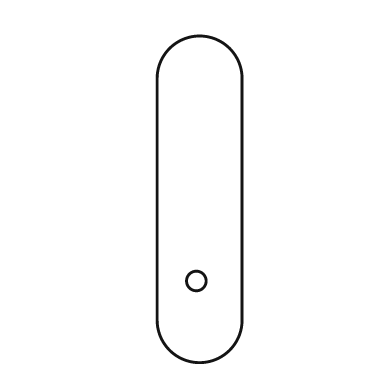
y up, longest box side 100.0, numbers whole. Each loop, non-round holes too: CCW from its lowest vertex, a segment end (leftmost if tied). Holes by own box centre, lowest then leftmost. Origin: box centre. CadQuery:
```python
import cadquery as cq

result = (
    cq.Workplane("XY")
    .moveTo(-13.0, -37.0)
    .threePointArc((0.0, -50.0), (13.0, -37.0))
    .lineTo(13.0, 37.0)
    .threePointArc((0.0, 50.0), (-13.0, 37.0))
    .close()
    .moveTo(-1.0, -25.0)
    .circle(3.0)
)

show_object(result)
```